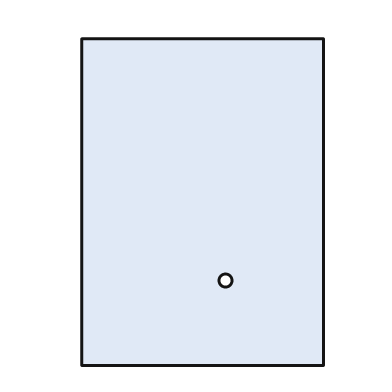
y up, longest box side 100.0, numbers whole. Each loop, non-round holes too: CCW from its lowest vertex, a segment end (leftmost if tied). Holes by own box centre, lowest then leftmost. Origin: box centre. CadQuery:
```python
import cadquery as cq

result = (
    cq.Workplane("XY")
    .moveTo(-37.0, -50.0)
    .lineTo(37.0, -50.0)
    .lineTo(37.0, 50.0)
    .lineTo(-37.0, 50.0)
    .close()
    .moveTo(7.0, -24.0)
    .circle(2.0)
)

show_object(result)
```